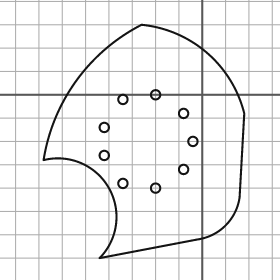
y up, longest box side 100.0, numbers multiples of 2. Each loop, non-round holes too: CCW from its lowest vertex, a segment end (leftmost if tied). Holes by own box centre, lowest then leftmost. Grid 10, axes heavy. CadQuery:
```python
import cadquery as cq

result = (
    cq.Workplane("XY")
    .moveTo(-44.0, -70.0)
    .lineTo(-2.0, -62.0)
    .threePointArc((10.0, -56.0), (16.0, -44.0))
    .lineTo(18.0, -8.0)
    .threePointArc((2.0, 18.0), (-26.0, 30.0))
    .threePointArc((-54.0, 6.0), (-68.0, -28.0))
    .threePointArc((-40.0, -40.0), (-44.0, -70.0))
    .close()
    .moveTo(-20.0, -40.0)
    .circle(2.0)
    .moveTo(-34.0, -38.0)
    .circle(2.0)
    .moveTo(-8.0, -32.0)
    .circle(2.0)
    .moveTo(-42.0, -26.0)
    .circle(2.0)
    .moveTo(-4.0, -20.0)
    .circle(2.0)
    .moveTo(-42.0, -14.0)
    .circle(2.0)
    .moveTo(-8.0, -8.0)
    .circle(2.0)
    .moveTo(-34.0, -2.0)
    .circle(2.0)
    .moveTo(-20.0, 0.0)
    .circle(2.0)
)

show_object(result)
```